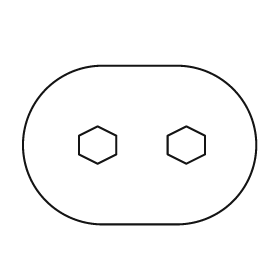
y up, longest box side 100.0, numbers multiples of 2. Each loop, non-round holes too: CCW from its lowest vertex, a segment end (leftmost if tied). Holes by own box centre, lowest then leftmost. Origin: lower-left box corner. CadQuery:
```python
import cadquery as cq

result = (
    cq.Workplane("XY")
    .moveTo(34.0, 0.0)
    .lineTo(66.0, 0.0)
    .threePointArc((100.0, 34.0), (66.0, 68.0))
    .lineTo(34.0, 68.0)
    .threePointArc((0.0, 34.0), (34.0, 0.0))
    .close()
    .moveTo(32.0, 26.0)
    .lineTo(40.0, 30.0)
    .lineTo(40.0, 38.0)
    .lineTo(32.0, 42.0)
    .lineTo(24.0, 38.0)
    .lineTo(24.0, 30.0)
    .close()
    .moveTo(70.0, 26.0)
    .lineTo(78.0, 30.0)
    .lineTo(78.0, 38.0)
    .lineTo(70.0, 42.0)
    .lineTo(62.0, 38.0)
    .lineTo(62.0, 30.0)
    .close()
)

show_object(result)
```